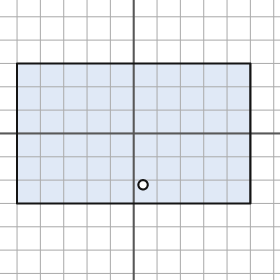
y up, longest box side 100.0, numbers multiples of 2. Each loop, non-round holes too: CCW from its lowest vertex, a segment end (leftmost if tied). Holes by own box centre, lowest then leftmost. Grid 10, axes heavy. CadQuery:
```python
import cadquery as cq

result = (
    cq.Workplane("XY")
    .moveTo(-50.0, -30.0)
    .lineTo(50.0, -30.0)
    .lineTo(50.0, 30.0)
    .lineTo(-50.0, 30.0)
    .close()
    .moveTo(4.0, -22.0)
    .circle(2.0)
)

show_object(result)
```